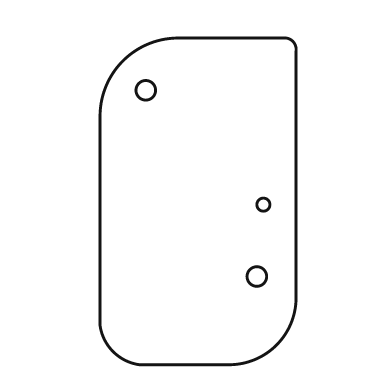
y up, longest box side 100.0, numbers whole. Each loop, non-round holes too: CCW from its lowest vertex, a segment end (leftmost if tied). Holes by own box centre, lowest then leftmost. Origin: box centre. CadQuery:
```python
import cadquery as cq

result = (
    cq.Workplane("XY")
    .moveTo(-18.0, -50.0)
    .lineTo(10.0, -50.0)
    .threePointArc((24.0, -44.0), (30.0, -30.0))
    .lineTo(30.0, 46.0)
    .threePointArc((29.0, 49.0), (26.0, 50.0))
    .lineTo(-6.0, 50.0)
    .threePointArc((-23.0, 43.0), (-30.0, 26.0))
    .lineTo(-30.0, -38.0)
    .threePointArc((-26.0, -46.0), (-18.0, -50.0))
    .close()
    .moveTo(18.0, -23.0)
    .circle(3.0)
    .moveTo(20.0, -1.0)
    .circle(2.0)
    .moveTo(-16.0, 34.0)
    .circle(3.0)
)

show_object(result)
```